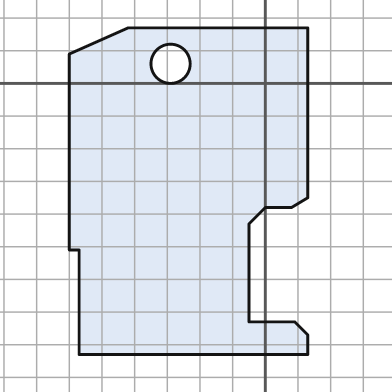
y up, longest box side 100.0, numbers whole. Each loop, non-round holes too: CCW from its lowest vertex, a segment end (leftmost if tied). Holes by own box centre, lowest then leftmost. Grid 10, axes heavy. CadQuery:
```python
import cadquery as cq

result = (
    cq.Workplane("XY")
    .moveTo(-57.0, -83.0)
    .lineTo(13.0, -83.0)
    .lineTo(13.0, -77.0)
    .lineTo(9.0, -73.0)
    .lineTo(-5.0, -73.0)
    .lineTo(-5.0, -43.0)
    .lineTo(0.0, -38.0)
    .lineTo(8.0, -38.0)
    .lineTo(13.0, -35.0)
    .lineTo(13.0, 17.0)
    .lineTo(-42.0, 17.0)
    .lineTo(-60.0, 9.0)
    .lineTo(-60.0, -51.0)
    .lineTo(-57.0, -51.0)
    .close()
    .moveTo(-29.0, 6.0)
    .circle(6.0)
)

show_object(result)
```